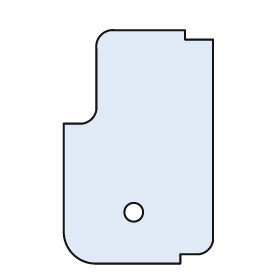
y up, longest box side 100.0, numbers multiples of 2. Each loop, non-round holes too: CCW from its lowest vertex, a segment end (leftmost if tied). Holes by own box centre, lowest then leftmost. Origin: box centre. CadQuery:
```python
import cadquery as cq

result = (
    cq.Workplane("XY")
    .moveTo(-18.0, -50.0)
    .lineTo(18.0, -50.0)
    .lineTo(18.0, -46.0)
    .lineTo(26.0, -46.0)
    .threePointArc((30.0, -44.0), (32.0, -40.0))
    .lineTo(32.0, 46.0)
    .lineTo(20.0, 46.0)
    .lineTo(20.0, 50.0)
    .lineTo(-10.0, 50.0)
    .threePointArc((-16.0, 48.0), (-18.0, 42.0))
    .lineTo(-18.0, 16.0)
    .threePointArc((-20.0, 12.0), (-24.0, 10.0))
    .lineTo(-32.0, 10.0)
    .lineTo(-32.0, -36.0)
    .threePointArc((-28.0, -46.0), (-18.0, -50.0))
    .close()
    .moveTo(-2.0, -28.0)
    .circle(4.0)
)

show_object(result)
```